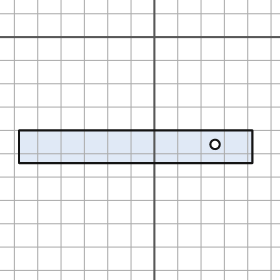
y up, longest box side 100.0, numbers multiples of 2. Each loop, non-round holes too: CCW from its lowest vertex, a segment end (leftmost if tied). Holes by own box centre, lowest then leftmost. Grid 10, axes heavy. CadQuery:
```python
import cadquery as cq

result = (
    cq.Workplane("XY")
    .moveTo(-58.0, -54.0)
    .lineTo(42.0, -54.0)
    .lineTo(42.0, -40.0)
    .lineTo(-58.0, -40.0)
    .close()
    .moveTo(26.0, -46.0)
    .circle(2.0)
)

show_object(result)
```